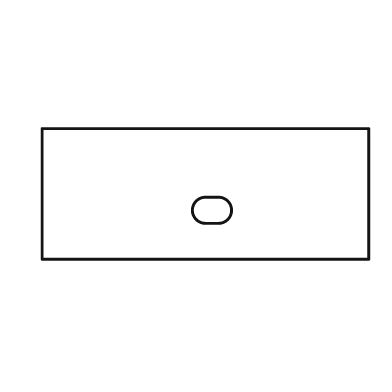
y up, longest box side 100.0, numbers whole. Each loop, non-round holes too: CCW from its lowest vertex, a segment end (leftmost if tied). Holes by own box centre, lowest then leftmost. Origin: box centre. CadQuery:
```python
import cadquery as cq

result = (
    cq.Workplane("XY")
    .moveTo(-50.0, -20.0)
    .lineTo(50.0, -20.0)
    .lineTo(50.0, 20.0)
    .lineTo(-50.0, 20.0)
    .close()
    .moveTo(0.0, -9.0)
    .lineTo(4.0, -9.0)
    .threePointArc((8.0, -5.0), (4.0, -1.0))
    .lineTo(0.0, -1.0)
    .threePointArc((-4.0, -5.0), (0.0, -9.0))
    .close()
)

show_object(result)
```